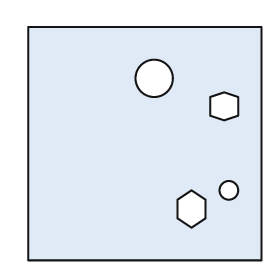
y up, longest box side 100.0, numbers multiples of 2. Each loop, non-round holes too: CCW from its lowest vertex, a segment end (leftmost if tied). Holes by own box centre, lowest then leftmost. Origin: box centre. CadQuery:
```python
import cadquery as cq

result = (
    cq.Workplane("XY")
    .moveTo(-50.0, -50.0)
    .lineTo(50.0, -50.0)
    .lineTo(50.0, 50.0)
    .lineTo(-50.0, 50.0)
    .close()
    .moveTo(20.0, -36.0)
    .lineTo(26.0, -32.0)
    .lineTo(26.0, -24.0)
    .lineTo(20.0, -20.0)
    .lineTo(14.0, -24.0)
    .lineTo(14.0, -32.0)
    .close()
    .moveTo(36.0, -20.0)
    .circle(4.0)
    .moveTo(34.0, 10.0)
    .lineTo(40.0, 12.0)
    .lineTo(40.0, 20.0)
    .lineTo(34.0, 22.0)
    .lineTo(28.0, 20.0)
    .lineTo(28.0, 12.0)
    .close()
    .moveTo(4.0, 28.0)
    .circle(8.0)
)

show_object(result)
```